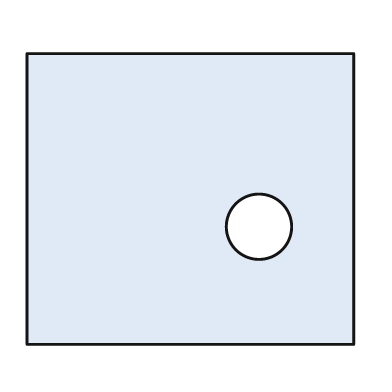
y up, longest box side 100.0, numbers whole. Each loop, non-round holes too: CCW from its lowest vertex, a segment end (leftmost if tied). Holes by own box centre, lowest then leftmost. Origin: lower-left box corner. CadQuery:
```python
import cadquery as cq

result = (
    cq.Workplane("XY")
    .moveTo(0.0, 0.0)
    .lineTo(100.0, 0.0)
    .lineTo(100.0, 89.0)
    .lineTo(0.0, 89.0)
    .close()
    .moveTo(71.0, 36.0)
    .circle(10.0)
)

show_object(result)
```